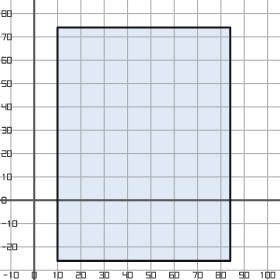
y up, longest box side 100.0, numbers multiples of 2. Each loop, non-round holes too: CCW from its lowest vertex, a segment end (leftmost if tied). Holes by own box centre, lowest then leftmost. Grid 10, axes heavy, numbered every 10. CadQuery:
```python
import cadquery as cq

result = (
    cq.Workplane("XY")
    .moveTo(10.0, -26.0)
    .lineTo(84.0, -26.0)
    .lineTo(84.0, 74.0)
    .lineTo(10.0, 74.0)
    .close()
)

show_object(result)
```